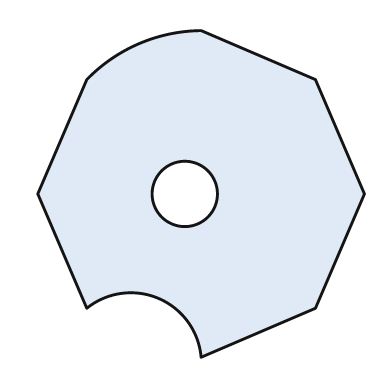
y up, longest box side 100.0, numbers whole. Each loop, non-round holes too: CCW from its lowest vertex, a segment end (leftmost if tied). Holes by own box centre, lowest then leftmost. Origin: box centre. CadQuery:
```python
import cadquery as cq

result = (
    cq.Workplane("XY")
    .moveTo(0.0, -50.0)
    .lineTo(35.0, -35.0)
    .lineTo(50.0, 0.0)
    .lineTo(35.0, 35.0)
    .lineTo(0.0, 50.0)
    .threePointArc((-19.0, 46.0), (-35.0, 35.0))
    .lineTo(-50.0, 0.0)
    .lineTo(-35.0, -35.0)
    .threePointArc((-13.0, -32.0), (0.0, -50.0))
    .close()
    .moveTo(-5.0, 0.0)
    .circle(10.0)
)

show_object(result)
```